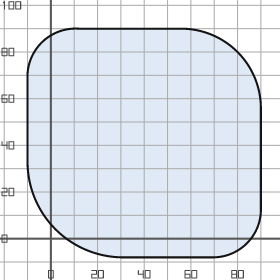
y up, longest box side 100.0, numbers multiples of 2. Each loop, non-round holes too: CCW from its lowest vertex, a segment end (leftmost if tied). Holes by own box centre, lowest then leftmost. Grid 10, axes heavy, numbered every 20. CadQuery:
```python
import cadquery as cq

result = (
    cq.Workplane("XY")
    .moveTo(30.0, -8.0)
    .lineTo(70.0, -8.0)
    .threePointArc((84.0, -2.0), (90.0, 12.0))
    .lineTo(90.0, 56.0)
    .threePointArc((80.0, 80.0), (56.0, 90.0))
    .lineTo(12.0, 90.0)
    .threePointArc((-4.0, 84.0), (-10.0, 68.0))
    .lineTo(-10.0, 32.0)
    .threePointArc((2.0, 4.0), (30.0, -8.0))
    .close()
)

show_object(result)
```